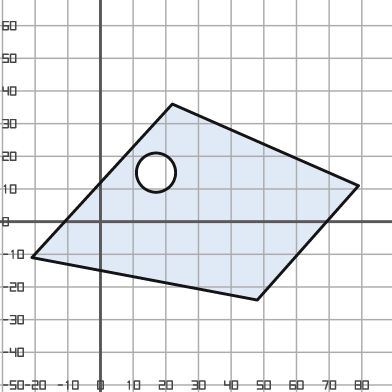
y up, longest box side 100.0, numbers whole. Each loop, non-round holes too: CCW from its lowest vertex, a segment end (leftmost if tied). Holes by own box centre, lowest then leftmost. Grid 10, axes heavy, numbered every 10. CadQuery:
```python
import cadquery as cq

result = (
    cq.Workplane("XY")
    .moveTo(48.0, -24.0)
    .lineTo(79.0, 11.0)
    .lineTo(22.0, 36.0)
    .lineTo(-21.0, -11.0)
    .close()
    .moveTo(17.0, 15.0)
    .circle(6.0)
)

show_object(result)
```